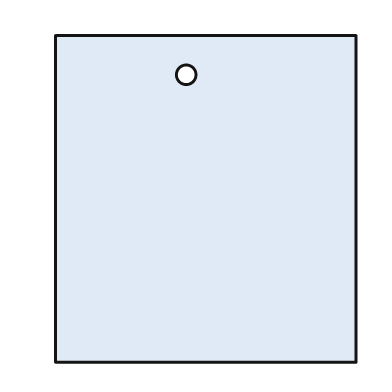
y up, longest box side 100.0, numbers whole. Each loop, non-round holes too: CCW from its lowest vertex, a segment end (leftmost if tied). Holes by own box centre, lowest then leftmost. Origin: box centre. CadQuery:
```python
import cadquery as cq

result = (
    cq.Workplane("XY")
    .moveTo(-46.0, -50.0)
    .lineTo(46.0, -50.0)
    .lineTo(46.0, 50.0)
    .lineTo(-46.0, 50.0)
    .close()
    .moveTo(-6.0, 38.0)
    .circle(3.0)
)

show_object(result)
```